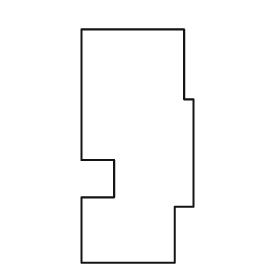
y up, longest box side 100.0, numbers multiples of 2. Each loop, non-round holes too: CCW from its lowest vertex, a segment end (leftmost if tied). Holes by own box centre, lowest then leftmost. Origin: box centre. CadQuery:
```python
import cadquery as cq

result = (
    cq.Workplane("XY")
    .moveTo(-24.0, -50.0)
    .lineTo(16.0, -50.0)
    .lineTo(16.0, -26.0)
    .lineTo(24.0, -26.0)
    .lineTo(24.0, 20.0)
    .lineTo(20.0, 20.0)
    .lineTo(20.0, 50.0)
    .lineTo(-24.0, 50.0)
    .lineTo(-24.0, -6.0)
    .lineTo(-10.0, -6.0)
    .lineTo(-10.0, -22.0)
    .lineTo(-24.0, -22.0)
    .close()
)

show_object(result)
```